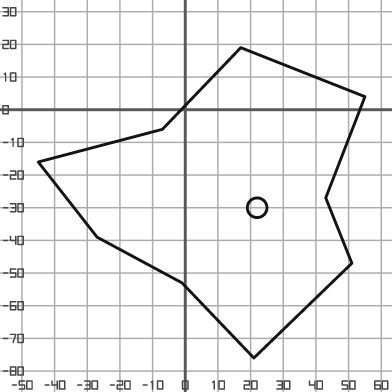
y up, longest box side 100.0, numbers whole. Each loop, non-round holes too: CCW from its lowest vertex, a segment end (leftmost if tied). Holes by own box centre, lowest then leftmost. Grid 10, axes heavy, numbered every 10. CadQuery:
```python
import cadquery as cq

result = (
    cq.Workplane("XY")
    .moveTo(21.0, -76.0)
    .lineTo(51.0, -47.0)
    .lineTo(43.0, -27.0)
    .lineTo(55.0, 4.0)
    .lineTo(17.0, 19.0)
    .lineTo(-7.0, -6.0)
    .lineTo(-45.0, -16.0)
    .lineTo(-27.0, -39.0)
    .lineTo(-1.0, -53.0)
    .close()
    .moveTo(22.0, -30.0)
    .circle(3.0)
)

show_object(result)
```